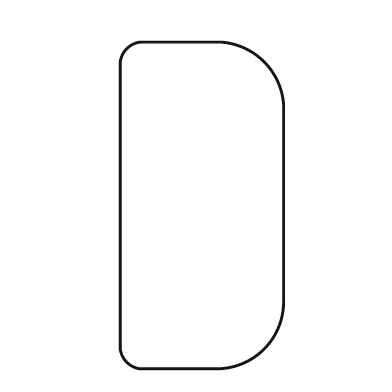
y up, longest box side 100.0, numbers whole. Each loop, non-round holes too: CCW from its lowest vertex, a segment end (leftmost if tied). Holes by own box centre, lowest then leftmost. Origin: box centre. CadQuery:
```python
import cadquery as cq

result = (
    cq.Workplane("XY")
    .moveTo(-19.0, -50.0)
    .lineTo(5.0, -50.0)
    .threePointArc((19.0, -44.0), (25.0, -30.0))
    .lineTo(25.0, 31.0)
    .threePointArc((19.0, 44.0), (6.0, 50.0))
    .lineTo(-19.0, 50.0)
    .threePointArc((-23.0, 48.0), (-25.0, 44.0))
    .lineTo(-25.0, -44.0)
    .threePointArc((-23.0, -48.0), (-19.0, -50.0))
    .close()
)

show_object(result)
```